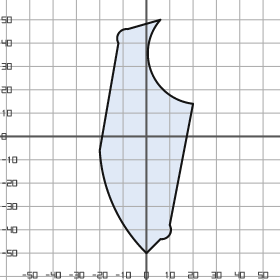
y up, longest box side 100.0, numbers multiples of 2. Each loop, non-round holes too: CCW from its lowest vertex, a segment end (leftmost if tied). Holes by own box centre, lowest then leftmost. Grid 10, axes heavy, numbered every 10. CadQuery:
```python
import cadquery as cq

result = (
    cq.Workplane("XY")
    .moveTo(0.0, -50.0)
    .lineTo(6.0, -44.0)
    .threePointArc((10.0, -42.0), (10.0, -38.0))
    .lineTo(20.0, 14.0)
    .threePointArc((2.0, 28.0), (6.0, 50.0))
    .lineTo(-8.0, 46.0)
    .threePointArc((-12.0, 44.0), (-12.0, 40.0))
    .lineTo(-20.0, -6.0)
    .threePointArc((-14.0, -30.0), (0.0, -50.0))
    .close()
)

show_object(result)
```